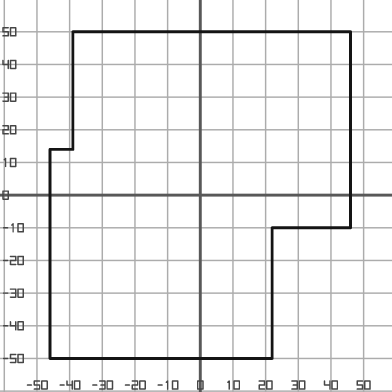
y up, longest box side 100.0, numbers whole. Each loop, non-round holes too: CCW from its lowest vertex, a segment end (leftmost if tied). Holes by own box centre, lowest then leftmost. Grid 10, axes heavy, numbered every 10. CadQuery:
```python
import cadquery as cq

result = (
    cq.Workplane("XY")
    .moveTo(-46.0, -50.0)
    .lineTo(22.0, -50.0)
    .lineTo(22.0, -10.0)
    .lineTo(46.0, -10.0)
    .lineTo(46.0, 50.0)
    .lineTo(-39.0, 50.0)
    .lineTo(-39.0, 14.0)
    .lineTo(-46.0, 14.0)
    .close()
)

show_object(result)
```